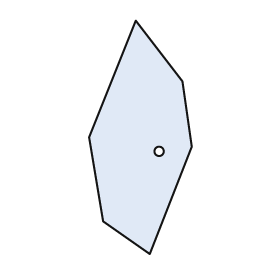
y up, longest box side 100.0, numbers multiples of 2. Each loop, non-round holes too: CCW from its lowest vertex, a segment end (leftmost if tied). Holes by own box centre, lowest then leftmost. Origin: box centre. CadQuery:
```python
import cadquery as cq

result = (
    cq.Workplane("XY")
    .moveTo(4.0, -50.0)
    .lineTo(22.0, -4.0)
    .lineTo(18.0, 24.0)
    .lineTo(-2.0, 50.0)
    .lineTo(-22.0, 0.0)
    .lineTo(-16.0, -36.0)
    .close()
    .moveTo(8.0, -6.0)
    .circle(2.0)
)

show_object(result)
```